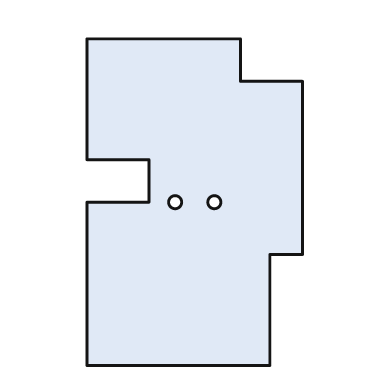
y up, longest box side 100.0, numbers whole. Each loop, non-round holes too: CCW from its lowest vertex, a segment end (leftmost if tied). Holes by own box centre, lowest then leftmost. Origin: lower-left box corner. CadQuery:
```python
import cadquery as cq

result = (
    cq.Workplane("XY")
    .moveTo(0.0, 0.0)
    .lineTo(56.0, 0.0)
    .lineTo(56.0, 34.0)
    .lineTo(66.0, 34.0)
    .lineTo(66.0, 87.0)
    .lineTo(47.0, 87.0)
    .lineTo(47.0, 100.0)
    .lineTo(0.0, 100.0)
    .lineTo(0.0, 63.0)
    .lineTo(19.0, 63.0)
    .lineTo(19.0, 50.0)
    .lineTo(0.0, 50.0)
    .close()
    .moveTo(27.0, 50.0)
    .circle(2.0)
    .moveTo(39.0, 50.0)
    .circle(2.0)
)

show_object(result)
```